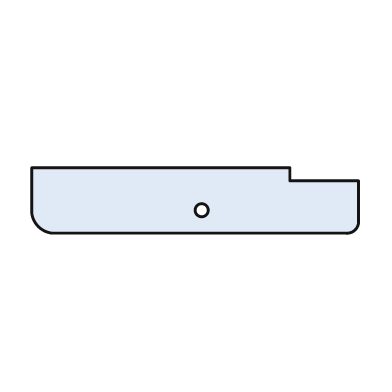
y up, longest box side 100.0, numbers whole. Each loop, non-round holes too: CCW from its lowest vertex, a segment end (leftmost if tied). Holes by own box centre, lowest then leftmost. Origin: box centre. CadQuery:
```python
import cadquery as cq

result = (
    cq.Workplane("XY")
    .moveTo(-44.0, -10.0)
    .lineTo(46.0, -10.0)
    .threePointArc((49.0, -9.0), (50.0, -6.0))
    .lineTo(50.0, 6.0)
    .lineTo(29.0, 6.0)
    .lineTo(29.0, 10.0)
    .lineTo(-50.0, 10.0)
    .lineTo(-50.0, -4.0)
    .threePointArc((-48.0, -8.0), (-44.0, -10.0))
    .close()
    .moveTo(2.0, -3.0)
    .circle(2.0)
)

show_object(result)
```